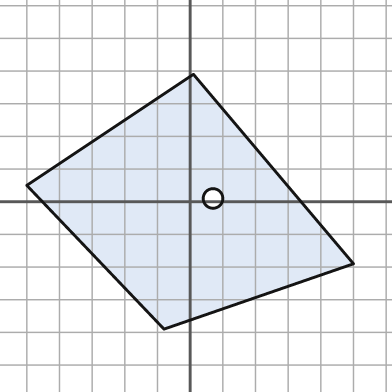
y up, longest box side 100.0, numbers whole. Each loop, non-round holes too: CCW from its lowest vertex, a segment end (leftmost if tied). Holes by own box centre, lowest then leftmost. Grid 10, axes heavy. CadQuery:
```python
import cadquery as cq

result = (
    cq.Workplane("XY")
    .moveTo(-8.0, -39.0)
    .lineTo(50.0, -19.0)
    .lineTo(1.0, 39.0)
    .lineTo(-50.0, 5.0)
    .close()
    .moveTo(7.0, 1.0)
    .circle(3.0)
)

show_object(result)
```